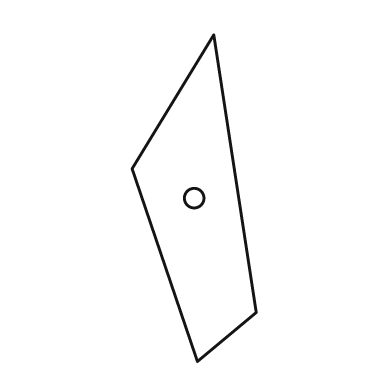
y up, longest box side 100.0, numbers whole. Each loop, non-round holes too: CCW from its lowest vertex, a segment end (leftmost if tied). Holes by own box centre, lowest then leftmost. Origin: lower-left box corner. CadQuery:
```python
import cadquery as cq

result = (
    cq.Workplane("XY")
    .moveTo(20.0, 0.0)
    .lineTo(38.0, 15.0)
    .lineTo(25.0, 100.0)
    .lineTo(0.0, 59.0)
    .close()
    .moveTo(19.0, 50.0)
    .circle(3.0)
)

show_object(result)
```